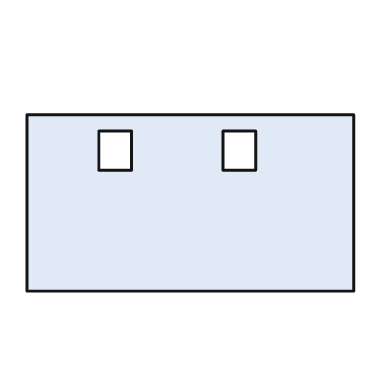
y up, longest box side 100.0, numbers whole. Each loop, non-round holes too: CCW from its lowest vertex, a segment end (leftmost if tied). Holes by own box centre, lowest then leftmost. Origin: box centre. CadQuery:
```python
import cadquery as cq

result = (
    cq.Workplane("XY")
    .moveTo(-50.0, -27.0)
    .lineTo(50.0, -27.0)
    .lineTo(50.0, 27.0)
    .lineTo(-50.0, 27.0)
    .close()
    .moveTo(-28.0, 10.0)
    .lineTo(-18.0, 10.0)
    .lineTo(-18.0, 22.0)
    .lineTo(-28.0, 22.0)
    .close()
    .moveTo(10.0, 10.0)
    .lineTo(20.0, 10.0)
    .lineTo(20.0, 22.0)
    .lineTo(10.0, 22.0)
    .close()
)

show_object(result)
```